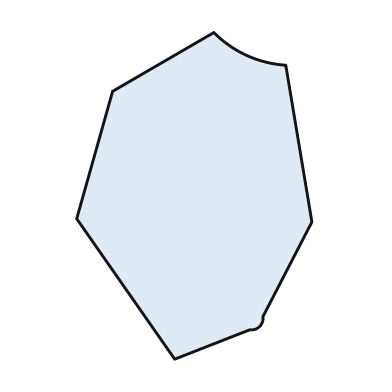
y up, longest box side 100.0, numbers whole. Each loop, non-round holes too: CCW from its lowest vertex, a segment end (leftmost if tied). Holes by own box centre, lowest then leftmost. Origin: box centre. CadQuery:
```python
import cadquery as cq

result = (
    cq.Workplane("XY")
    .moveTo(-6.0, -50.0)
    .lineTo(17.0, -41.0)
    .threePointArc((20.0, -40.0), (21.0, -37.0))
    .lineTo(36.0, -8.0)
    .lineTo(28.0, 40.0)
    .threePointArc((16.0, 43.0), (6.0, 50.0))
    .lineTo(-25.0, 32.0)
    .lineTo(-36.0, -7.0)
    .close()
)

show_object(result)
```